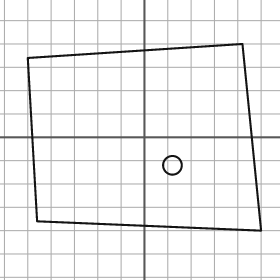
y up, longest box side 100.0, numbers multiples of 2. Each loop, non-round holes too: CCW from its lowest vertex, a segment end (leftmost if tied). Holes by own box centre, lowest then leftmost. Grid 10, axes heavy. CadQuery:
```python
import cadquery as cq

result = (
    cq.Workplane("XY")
    .moveTo(50.0, -40.0)
    .lineTo(42.0, 40.0)
    .lineTo(-50.0, 34.0)
    .lineTo(-46.0, -36.0)
    .close()
    .moveTo(12.0, -12.0)
    .circle(4.0)
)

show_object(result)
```